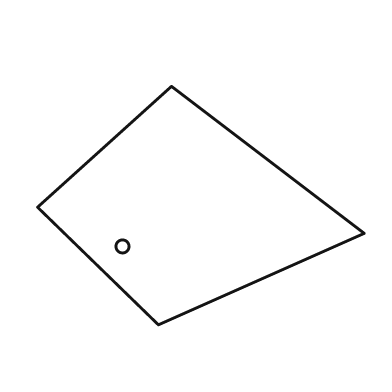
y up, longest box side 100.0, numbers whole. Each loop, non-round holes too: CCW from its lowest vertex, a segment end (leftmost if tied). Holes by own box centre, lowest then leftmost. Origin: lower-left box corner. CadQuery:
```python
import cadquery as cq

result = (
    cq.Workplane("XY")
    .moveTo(37.0, 0.0)
    .lineTo(100.0, 28.0)
    .lineTo(41.0, 73.0)
    .lineTo(0.0, 36.0)
    .close()
    .moveTo(26.0, 24.0)
    .circle(2.0)
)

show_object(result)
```